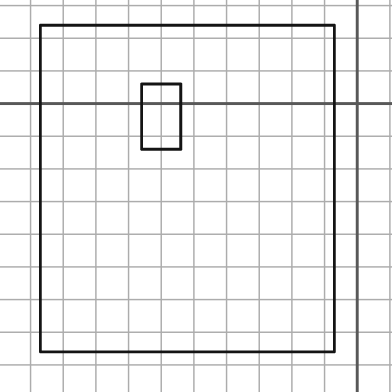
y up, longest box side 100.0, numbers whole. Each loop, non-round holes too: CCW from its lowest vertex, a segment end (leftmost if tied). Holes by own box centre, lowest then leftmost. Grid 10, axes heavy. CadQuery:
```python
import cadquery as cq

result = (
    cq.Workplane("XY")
    .moveTo(-97.0, -76.0)
    .lineTo(-7.0, -76.0)
    .lineTo(-7.0, 24.0)
    .lineTo(-97.0, 24.0)
    .close()
    .moveTo(-66.0, -14.0)
    .lineTo(-54.0, -14.0)
    .lineTo(-54.0, 6.0)
    .lineTo(-66.0, 6.0)
    .close()
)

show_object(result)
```